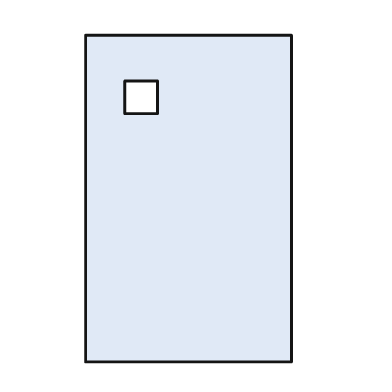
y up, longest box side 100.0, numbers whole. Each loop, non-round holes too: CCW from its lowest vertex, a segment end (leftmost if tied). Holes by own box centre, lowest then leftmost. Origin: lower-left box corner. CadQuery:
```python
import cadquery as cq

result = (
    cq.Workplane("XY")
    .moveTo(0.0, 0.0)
    .lineTo(63.0, 0.0)
    .lineTo(63.0, 100.0)
    .lineTo(0.0, 100.0)
    .close()
    .moveTo(12.0, 76.0)
    .lineTo(22.0, 76.0)
    .lineTo(22.0, 86.0)
    .lineTo(12.0, 86.0)
    .close()
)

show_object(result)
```